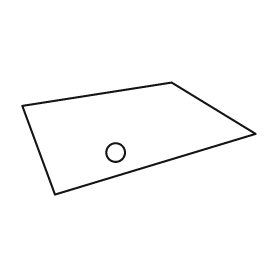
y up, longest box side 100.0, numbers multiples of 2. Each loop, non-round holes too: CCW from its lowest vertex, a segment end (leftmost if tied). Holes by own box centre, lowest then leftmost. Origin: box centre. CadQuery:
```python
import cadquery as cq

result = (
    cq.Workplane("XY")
    .moveTo(-36.0, -24.0)
    .lineTo(50.0, 2.0)
    .lineTo(14.0, 24.0)
    .lineTo(-50.0, 14.0)
    .close()
    .moveTo(-10.0, -6.0)
    .circle(4.0)
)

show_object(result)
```